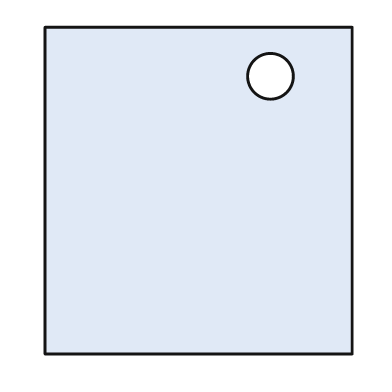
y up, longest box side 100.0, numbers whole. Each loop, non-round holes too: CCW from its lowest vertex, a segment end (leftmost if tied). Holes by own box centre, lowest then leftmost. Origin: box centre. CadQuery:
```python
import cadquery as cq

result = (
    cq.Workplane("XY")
    .moveTo(-47.0, -50.0)
    .lineTo(47.0, -50.0)
    .lineTo(47.0, 50.0)
    .lineTo(-47.0, 50.0)
    .close()
    .moveTo(22.0, 35.0)
    .circle(7.0)
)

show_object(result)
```